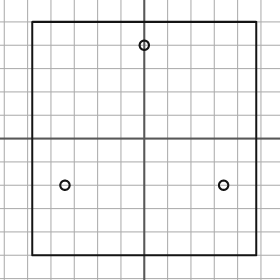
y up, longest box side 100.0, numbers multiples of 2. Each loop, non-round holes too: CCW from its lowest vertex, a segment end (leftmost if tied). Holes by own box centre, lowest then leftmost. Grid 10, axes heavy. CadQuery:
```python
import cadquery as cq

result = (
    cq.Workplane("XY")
    .moveTo(-48.0, -50.0)
    .lineTo(48.0, -50.0)
    .lineTo(48.0, 50.0)
    .lineTo(-48.0, 50.0)
    .close()
    .moveTo(-34.0, -20.0)
    .circle(2.0)
    .moveTo(34.0, -20.0)
    .circle(2.0)
    .moveTo(0.0, 40.0)
    .circle(2.0)
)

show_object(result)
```